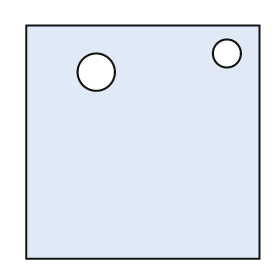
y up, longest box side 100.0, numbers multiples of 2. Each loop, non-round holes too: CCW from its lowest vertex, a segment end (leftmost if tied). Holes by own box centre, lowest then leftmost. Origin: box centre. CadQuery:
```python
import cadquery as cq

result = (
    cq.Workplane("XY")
    .moveTo(-50.0, -50.0)
    .lineTo(50.0, -50.0)
    .lineTo(50.0, 50.0)
    .lineTo(-50.0, 50.0)
    .close()
    .moveTo(-20.0, 30.0)
    .circle(8.0)
    .moveTo(36.0, 38.0)
    .circle(6.0)
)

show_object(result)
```